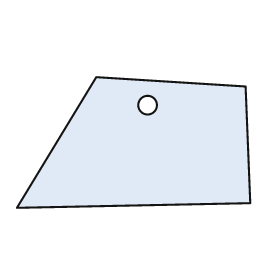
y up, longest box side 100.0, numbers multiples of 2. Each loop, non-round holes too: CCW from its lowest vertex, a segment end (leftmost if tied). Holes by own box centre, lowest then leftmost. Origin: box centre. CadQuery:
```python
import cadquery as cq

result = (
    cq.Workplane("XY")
    .moveTo(-50.0, -28.0)
    .lineTo(50.0, -26.0)
    .lineTo(48.0, 24.0)
    .lineTo(-16.0, 28.0)
    .close()
    .moveTo(6.0, 16.0)
    .circle(4.0)
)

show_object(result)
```